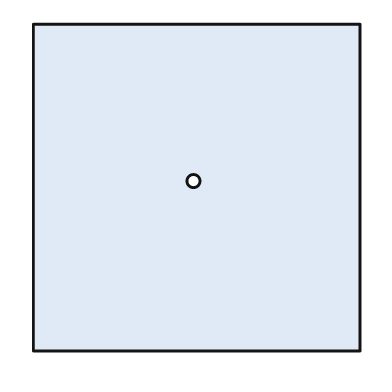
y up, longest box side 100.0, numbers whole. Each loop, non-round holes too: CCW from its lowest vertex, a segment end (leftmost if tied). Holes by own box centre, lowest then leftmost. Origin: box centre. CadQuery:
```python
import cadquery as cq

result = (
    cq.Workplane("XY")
    .moveTo(-50.0, -50.0)
    .lineTo(50.0, -50.0)
    .lineTo(50.0, 50.0)
    .lineTo(-50.0, 50.0)
    .close()
    .moveTo(-1.0, 2.0)
    .circle(2.0)
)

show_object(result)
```